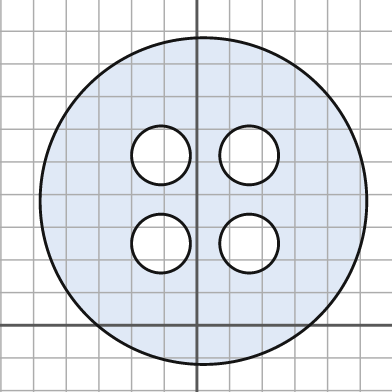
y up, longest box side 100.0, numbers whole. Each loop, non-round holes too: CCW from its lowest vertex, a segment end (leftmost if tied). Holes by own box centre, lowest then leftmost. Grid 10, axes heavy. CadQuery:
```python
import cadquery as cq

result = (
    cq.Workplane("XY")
    .moveTo(2.0, 38.0)
    .circle(50.0)
    .moveTo(-11.0, 25.0)
    .circle(9.0)
    .moveTo(16.0, 25.0)
    .circle(9.0)
    .moveTo(-11.0, 52.0)
    .circle(9.0)
    .moveTo(16.0, 52.0)
    .circle(9.0)
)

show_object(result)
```